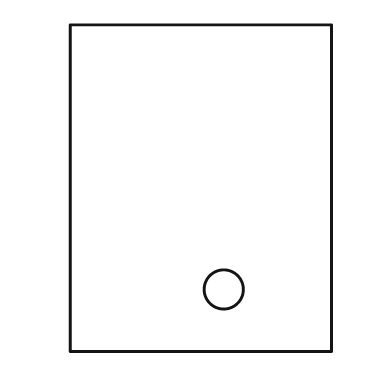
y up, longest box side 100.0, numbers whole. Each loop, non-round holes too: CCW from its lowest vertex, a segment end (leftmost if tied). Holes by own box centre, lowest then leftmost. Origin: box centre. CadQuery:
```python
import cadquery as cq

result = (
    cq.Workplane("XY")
    .moveTo(-40.0, -50.0)
    .lineTo(40.0, -50.0)
    .lineTo(40.0, 50.0)
    .lineTo(-40.0, 50.0)
    .close()
    .moveTo(7.0, -31.0)
    .circle(6.0)
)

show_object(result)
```